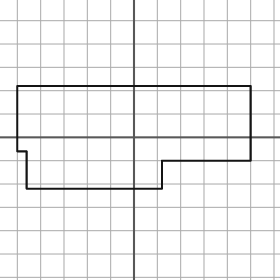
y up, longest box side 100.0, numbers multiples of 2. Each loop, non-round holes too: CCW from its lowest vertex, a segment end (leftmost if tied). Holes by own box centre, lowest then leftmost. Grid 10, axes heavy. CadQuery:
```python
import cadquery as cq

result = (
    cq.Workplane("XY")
    .moveTo(-46.0, -22.0)
    .lineTo(12.0, -22.0)
    .lineTo(12.0, -10.0)
    .lineTo(50.0, -10.0)
    .lineTo(50.0, 22.0)
    .lineTo(-50.0, 22.0)
    .lineTo(-50.0, -6.0)
    .lineTo(-46.0, -6.0)
    .close()
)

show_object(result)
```